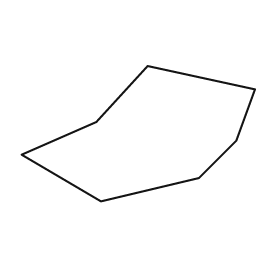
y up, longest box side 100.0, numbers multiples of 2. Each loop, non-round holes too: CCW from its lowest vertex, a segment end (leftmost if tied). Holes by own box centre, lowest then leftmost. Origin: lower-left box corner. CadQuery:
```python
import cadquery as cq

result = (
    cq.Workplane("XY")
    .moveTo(34.0, 0.0)
    .lineTo(76.0, 10.0)
    .lineTo(92.0, 26.0)
    .lineTo(100.0, 48.0)
    .lineTo(54.0, 58.0)
    .lineTo(32.0, 34.0)
    .lineTo(0.0, 20.0)
    .close()
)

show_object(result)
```